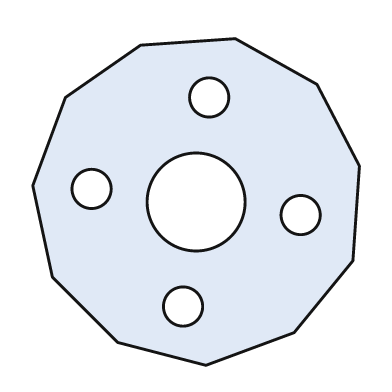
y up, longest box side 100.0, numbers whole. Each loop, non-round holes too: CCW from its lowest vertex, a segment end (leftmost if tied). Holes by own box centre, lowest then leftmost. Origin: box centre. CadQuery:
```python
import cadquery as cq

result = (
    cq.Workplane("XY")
    .moveTo(3.0, -50.0)
    .lineTo(30.0, -40.0)
    .lineTo(48.0, -18.0)
    .lineTo(50.0, 11.0)
    .lineTo(37.0, 36.0)
    .lineTo(12.0, 50.0)
    .lineTo(-17.0, 48.0)
    .lineTo(-40.0, 32.0)
    .lineTo(-50.0, 5.0)
    .lineTo(-44.0, -23.0)
    .lineTo(-24.0, -43.0)
    .close()
    .moveTo(-4.0, -32.0)
    .circle(6.0)
    .moveTo(32.0, -4.0)
    .circle(6.0)
    .moveTo(0.0, 0.0)
    .circle(15.0)
    .moveTo(-32.0, 4.0)
    .circle(6.0)
    .moveTo(4.0, 32.0)
    .circle(6.0)
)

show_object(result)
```